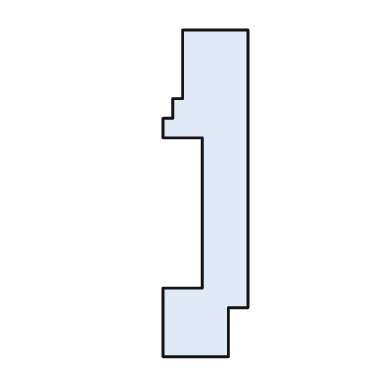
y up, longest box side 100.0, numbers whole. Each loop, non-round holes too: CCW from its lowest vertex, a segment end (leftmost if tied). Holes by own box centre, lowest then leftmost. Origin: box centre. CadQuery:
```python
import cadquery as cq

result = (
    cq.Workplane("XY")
    .moveTo(-13.0, -50.0)
    .lineTo(7.0, -50.0)
    .lineTo(7.0, -35.0)
    .lineTo(13.0, -35.0)
    .lineTo(13.0, 50.0)
    .lineTo(-7.0, 50.0)
    .lineTo(-7.0, 29.0)
    .lineTo(-10.0, 29.0)
    .lineTo(-10.0, 23.0)
    .lineTo(-13.0, 23.0)
    .lineTo(-13.0, 17.0)
    .lineTo(-1.0, 17.0)
    .lineTo(-1.0, -29.0)
    .lineTo(-13.0, -29.0)
    .close()
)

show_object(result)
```